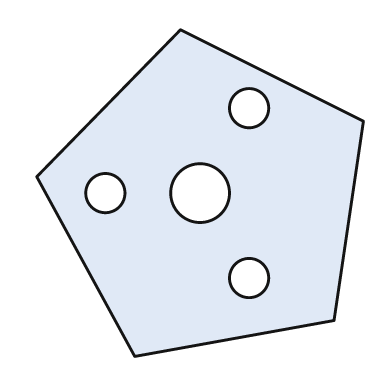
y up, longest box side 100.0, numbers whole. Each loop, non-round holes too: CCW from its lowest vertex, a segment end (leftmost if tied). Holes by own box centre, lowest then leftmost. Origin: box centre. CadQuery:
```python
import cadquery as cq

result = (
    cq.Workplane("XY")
    .moveTo(-20.0, -50.0)
    .lineTo(41.0, -39.0)
    .lineTo(50.0, 22.0)
    .lineTo(-6.0, 50.0)
    .lineTo(-50.0, 5.0)
    .close()
    .moveTo(15.0, -26.0)
    .circle(6.0)
    .moveTo(-29.0, 0.0)
    .circle(6.0)
    .moveTo(0.0, 0.0)
    .circle(9.0)
    .moveTo(15.0, 26.0)
    .circle(6.0)
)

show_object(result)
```